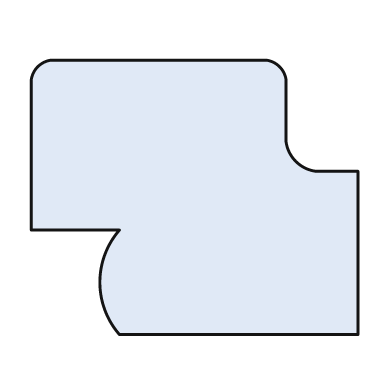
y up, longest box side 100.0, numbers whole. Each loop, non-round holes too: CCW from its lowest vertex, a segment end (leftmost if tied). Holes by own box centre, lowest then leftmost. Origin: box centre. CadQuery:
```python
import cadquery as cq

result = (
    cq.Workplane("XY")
    .moveTo(-23.0, -42.0)
    .lineTo(50.0, -42.0)
    .lineTo(50.0, 8.0)
    .lineTo(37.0, 8.0)
    .threePointArc((31.0, 11.0), (28.0, 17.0))
    .lineTo(28.0, 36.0)
    .threePointArc((26.0, 40.0), (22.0, 42.0))
    .lineTo(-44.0, 42.0)
    .threePointArc((-48.0, 40.0), (-50.0, 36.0))
    .lineTo(-50.0, -10.0)
    .lineTo(-23.0, -10.0)
    .threePointArc((-29.0, -26.0), (-23.0, -42.0))
    .close()
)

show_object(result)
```